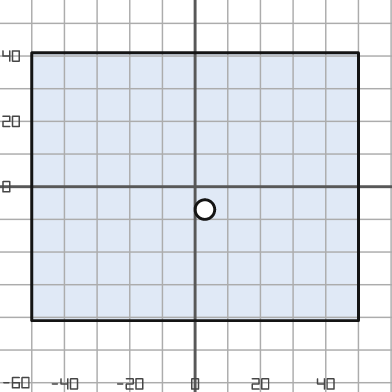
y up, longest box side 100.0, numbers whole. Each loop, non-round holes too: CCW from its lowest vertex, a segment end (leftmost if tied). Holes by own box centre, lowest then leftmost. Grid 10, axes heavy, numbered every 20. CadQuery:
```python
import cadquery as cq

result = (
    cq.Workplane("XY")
    .moveTo(-50.0, -41.0)
    .lineTo(50.0, -41.0)
    .lineTo(50.0, 41.0)
    .lineTo(-50.0, 41.0)
    .close()
    .moveTo(3.0, -7.0)
    .circle(3.0)
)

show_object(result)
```